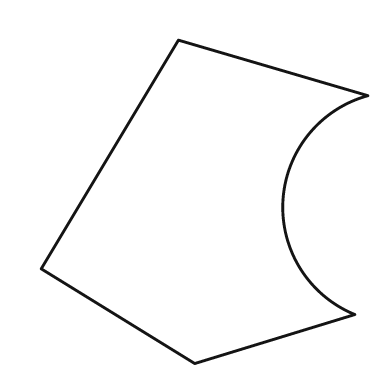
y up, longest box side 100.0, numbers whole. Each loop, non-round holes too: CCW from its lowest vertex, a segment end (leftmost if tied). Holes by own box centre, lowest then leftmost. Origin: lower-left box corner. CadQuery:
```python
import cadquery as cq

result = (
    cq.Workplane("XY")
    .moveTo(47.0, 0.0)
    .lineTo(96.0, 15.0)
    .threePointArc((74.0, 50.0), (100.0, 82.0))
    .lineTo(42.0, 99.0)
    .lineTo(0.0, 29.0)
    .close()
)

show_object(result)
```